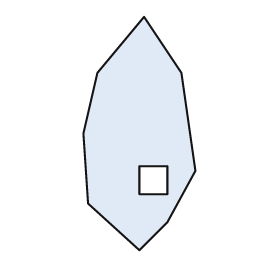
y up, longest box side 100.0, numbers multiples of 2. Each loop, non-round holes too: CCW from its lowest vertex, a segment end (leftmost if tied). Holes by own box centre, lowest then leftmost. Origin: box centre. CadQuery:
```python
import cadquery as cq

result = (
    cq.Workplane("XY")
    .moveTo(0.0, -50.0)
    .lineTo(12.0, -38.0)
    .lineTo(24.0, -16.0)
    .lineTo(18.0, 26.0)
    .lineTo(2.0, 50.0)
    .lineTo(-18.0, 26.0)
    .lineTo(-24.0, 0.0)
    .lineTo(-22.0, -30.0)
    .close()
    .moveTo(0.0, -26.0)
    .lineTo(12.0, -26.0)
    .lineTo(12.0, -14.0)
    .lineTo(0.0, -14.0)
    .close()
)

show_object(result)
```